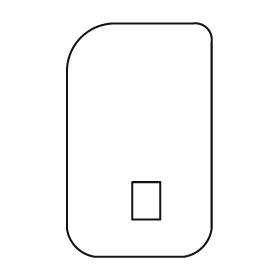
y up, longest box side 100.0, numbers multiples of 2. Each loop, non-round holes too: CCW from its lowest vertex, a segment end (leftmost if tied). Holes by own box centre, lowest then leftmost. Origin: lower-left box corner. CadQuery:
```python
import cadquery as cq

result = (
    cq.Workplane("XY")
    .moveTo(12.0, 0.0)
    .lineTo(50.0, 0.0)
    .threePointArc((58.0, 4.0), (62.0, 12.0))
    .lineTo(62.0, 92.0)
    .threePointArc((60.0, 98.0), (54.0, 100.0))
    .lineTo(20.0, 100.0)
    .threePointArc((6.0, 94.0), (0.0, 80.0))
    .lineTo(0.0, 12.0)
    .threePointArc((4.0, 4.0), (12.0, 0.0))
    .close()
    .moveTo(28.0, 16.0)
    .lineTo(40.0, 16.0)
    .lineTo(40.0, 32.0)
    .lineTo(28.0, 32.0)
    .close()
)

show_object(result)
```